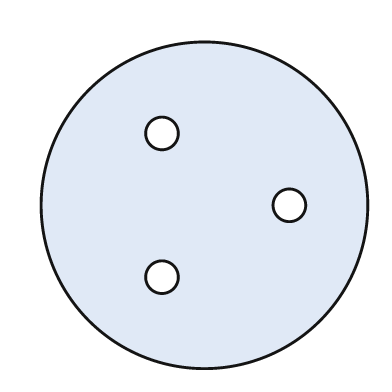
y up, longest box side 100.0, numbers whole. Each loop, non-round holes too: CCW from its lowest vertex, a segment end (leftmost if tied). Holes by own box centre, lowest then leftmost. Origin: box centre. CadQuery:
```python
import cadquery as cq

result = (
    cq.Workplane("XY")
    .moveTo(0.0, 0.0)
    .circle(50.0)
    .moveTo(-13.0, -22.0)
    .circle(5.0)
    .moveTo(26.0, 0.0)
    .circle(5.0)
    .moveTo(-13.0, 22.0)
    .circle(5.0)
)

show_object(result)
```